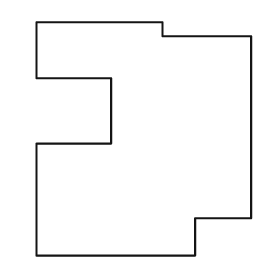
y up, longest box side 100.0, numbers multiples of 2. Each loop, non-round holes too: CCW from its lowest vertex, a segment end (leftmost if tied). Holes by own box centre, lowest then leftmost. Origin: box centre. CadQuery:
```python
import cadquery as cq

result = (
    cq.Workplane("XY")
    .moveTo(-46.0, -50.0)
    .lineTo(22.0, -50.0)
    .lineTo(22.0, -34.0)
    .lineTo(46.0, -34.0)
    .lineTo(46.0, 44.0)
    .lineTo(8.0, 44.0)
    .lineTo(8.0, 50.0)
    .lineTo(-46.0, 50.0)
    .lineTo(-46.0, 26.0)
    .lineTo(-14.0, 26.0)
    .lineTo(-14.0, -2.0)
    .lineTo(-46.0, -2.0)
    .close()
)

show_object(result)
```